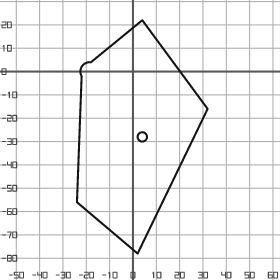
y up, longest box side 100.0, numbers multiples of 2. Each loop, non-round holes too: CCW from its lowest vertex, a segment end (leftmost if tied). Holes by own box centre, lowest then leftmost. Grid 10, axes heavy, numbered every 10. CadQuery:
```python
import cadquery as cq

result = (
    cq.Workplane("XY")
    .moveTo(2.0, -78.0)
    .lineTo(32.0, -16.0)
    .lineTo(4.0, 22.0)
    .lineTo(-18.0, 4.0)
    .threePointArc((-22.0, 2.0), (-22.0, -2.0))
    .lineTo(-24.0, -56.0)
    .close()
    .moveTo(4.0, -28.0)
    .circle(2.0)
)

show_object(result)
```